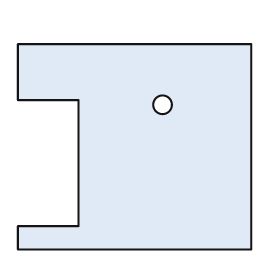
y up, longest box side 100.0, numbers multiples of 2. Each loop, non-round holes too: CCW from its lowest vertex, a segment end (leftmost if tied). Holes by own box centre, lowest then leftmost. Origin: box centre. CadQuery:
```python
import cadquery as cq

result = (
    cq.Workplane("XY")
    .moveTo(-50.0, -44.0)
    .lineTo(50.0, -44.0)
    .lineTo(50.0, 44.0)
    .lineTo(-50.0, 44.0)
    .lineTo(-50.0, 20.0)
    .lineTo(-24.0, 20.0)
    .lineTo(-24.0, -34.0)
    .lineTo(-50.0, -34.0)
    .close()
    .moveTo(12.0, 18.0)
    .circle(4.0)
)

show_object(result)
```